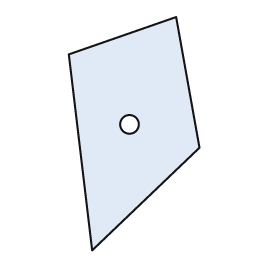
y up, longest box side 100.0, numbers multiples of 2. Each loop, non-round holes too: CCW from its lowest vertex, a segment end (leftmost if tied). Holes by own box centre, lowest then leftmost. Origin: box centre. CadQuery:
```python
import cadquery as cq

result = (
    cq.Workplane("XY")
    .moveTo(-18.0, -50.0)
    .lineTo(28.0, -6.0)
    .lineTo(18.0, 50.0)
    .lineTo(-28.0, 34.0)
    .close()
    .moveTo(-2.0, 4.0)
    .circle(4.0)
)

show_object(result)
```